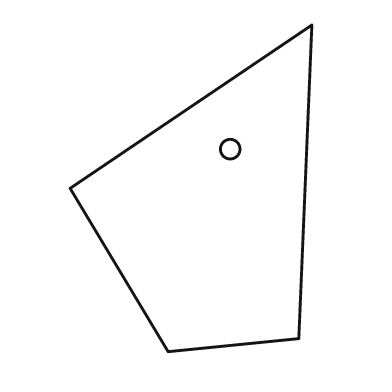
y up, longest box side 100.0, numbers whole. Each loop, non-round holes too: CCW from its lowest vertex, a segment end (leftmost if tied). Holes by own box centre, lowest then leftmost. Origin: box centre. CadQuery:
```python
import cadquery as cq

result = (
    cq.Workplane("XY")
    .moveTo(-7.0, -50.0)
    .lineTo(33.0, -46.0)
    .lineTo(37.0, 50.0)
    .lineTo(-37.0, 0.0)
    .close()
    .moveTo(12.0, 12.0)
    .circle(3.0)
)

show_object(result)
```